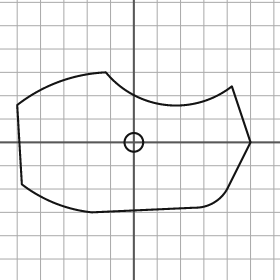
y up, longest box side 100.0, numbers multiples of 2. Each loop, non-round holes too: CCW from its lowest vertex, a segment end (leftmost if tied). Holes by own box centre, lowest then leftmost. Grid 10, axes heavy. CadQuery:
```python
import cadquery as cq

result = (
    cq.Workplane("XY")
    .moveTo(-18.0, -30.0)
    .lineTo(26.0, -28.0)
    .threePointArc((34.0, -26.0), (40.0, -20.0))
    .lineTo(50.0, 0.0)
    .lineTo(42.0, 24.0)
    .threePointArc((14.0, 16.0), (-12.0, 30.0))
    .threePointArc((-32.0, 26.0), (-50.0, 16.0))
    .lineTo(-48.0, -18.0)
    .threePointArc((-34.0, -26.0), (-18.0, -30.0))
    .close()
    .moveTo(0.0, 0.0)
    .circle(4.0)
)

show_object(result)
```